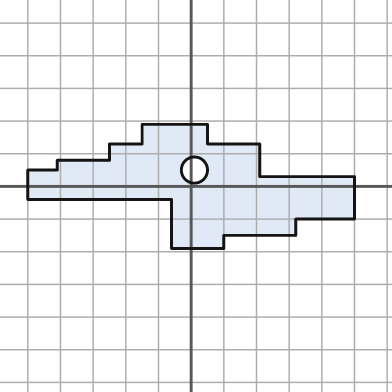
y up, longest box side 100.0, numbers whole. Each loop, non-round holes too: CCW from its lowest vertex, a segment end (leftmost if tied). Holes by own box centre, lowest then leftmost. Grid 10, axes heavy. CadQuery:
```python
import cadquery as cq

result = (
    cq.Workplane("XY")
    .moveTo(-6.0, -19.0)
    .lineTo(10.0, -19.0)
    .lineTo(10.0, -15.0)
    .lineTo(32.0, -15.0)
    .lineTo(32.0, -10.0)
    .lineTo(50.0, -10.0)
    .lineTo(50.0, 3.0)
    .lineTo(21.0, 3.0)
    .lineTo(21.0, 13.0)
    .lineTo(5.0, 13.0)
    .lineTo(5.0, 19.0)
    .lineTo(-15.0, 19.0)
    .lineTo(-15.0, 13.0)
    .lineTo(-25.0, 13.0)
    .lineTo(-25.0, 8.0)
    .lineTo(-41.0, 8.0)
    .lineTo(-41.0, 5.0)
    .lineTo(-50.0, 5.0)
    .lineTo(-50.0, -4.0)
    .lineTo(-6.0, -4.0)
    .close()
    .moveTo(1.0, 5.0)
    .circle(4.0)
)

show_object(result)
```